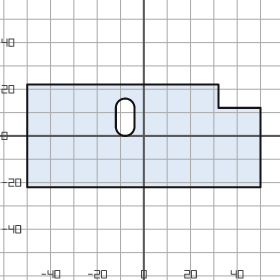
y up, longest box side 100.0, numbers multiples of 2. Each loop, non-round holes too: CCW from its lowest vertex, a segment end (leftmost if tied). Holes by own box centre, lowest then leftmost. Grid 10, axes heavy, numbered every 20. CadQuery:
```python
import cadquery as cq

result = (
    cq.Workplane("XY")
    .moveTo(-50.0, -22.0)
    .lineTo(50.0, -22.0)
    .lineTo(50.0, 12.0)
    .lineTo(32.0, 12.0)
    .lineTo(32.0, 22.0)
    .lineTo(-50.0, 22.0)
    .close()
    .moveTo(-12.0, 4.0)
    .threePointArc((-8.0, 0.0), (-4.0, 4.0))
    .lineTo(-4.0, 12.0)
    .threePointArc((-8.0, 16.0), (-12.0, 12.0))
    .close()
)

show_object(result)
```